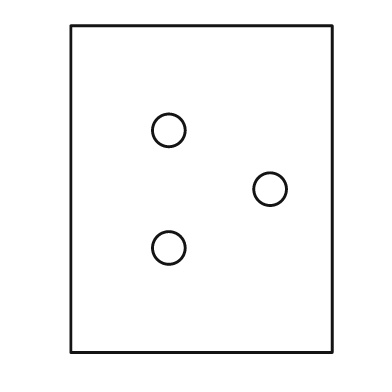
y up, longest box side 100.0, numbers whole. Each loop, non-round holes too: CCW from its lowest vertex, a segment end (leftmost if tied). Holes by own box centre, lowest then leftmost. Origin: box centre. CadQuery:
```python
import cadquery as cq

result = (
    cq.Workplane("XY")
    .moveTo(-40.0, -50.0)
    .lineTo(40.0, -50.0)
    .lineTo(40.0, 50.0)
    .lineTo(-40.0, 50.0)
    .close()
    .moveTo(-10.0, -18.0)
    .circle(5.0)
    .moveTo(21.0, 0.0)
    .circle(5.0)
    .moveTo(-10.0, 18.0)
    .circle(5.0)
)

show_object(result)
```